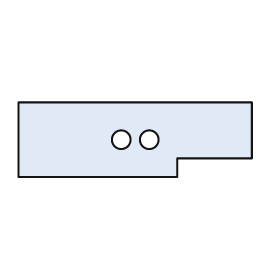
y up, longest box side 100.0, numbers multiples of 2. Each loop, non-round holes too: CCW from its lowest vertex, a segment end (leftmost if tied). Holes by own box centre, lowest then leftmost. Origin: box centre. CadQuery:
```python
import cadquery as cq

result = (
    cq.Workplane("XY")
    .moveTo(-50.0, -16.0)
    .lineTo(18.0, -16.0)
    .lineTo(18.0, -8.0)
    .lineTo(50.0, -8.0)
    .lineTo(50.0, 16.0)
    .lineTo(-50.0, 16.0)
    .close()
    .moveTo(-6.0, 0.0)
    .circle(4.0)
    .moveTo(6.0, 0.0)
    .circle(4.0)
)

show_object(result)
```